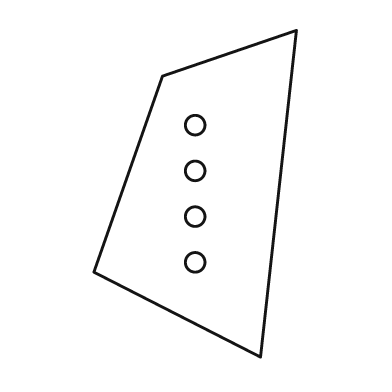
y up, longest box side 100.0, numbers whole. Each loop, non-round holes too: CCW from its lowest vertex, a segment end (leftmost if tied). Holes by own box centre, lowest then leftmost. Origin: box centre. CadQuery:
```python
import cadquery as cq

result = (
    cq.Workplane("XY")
    .moveTo(20.0, -50.0)
    .lineTo(31.0, 50.0)
    .lineTo(-10.0, 36.0)
    .lineTo(-31.0, -24.0)
    .close()
    .moveTo(0.0, -21.0)
    .circle(3.0)
    .moveTo(0.0, -7.0)
    .circle(3.0)
    .moveTo(0.0, 7.0)
    .circle(3.0)
    .moveTo(0.0, 21.0)
    .circle(3.0)
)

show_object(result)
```